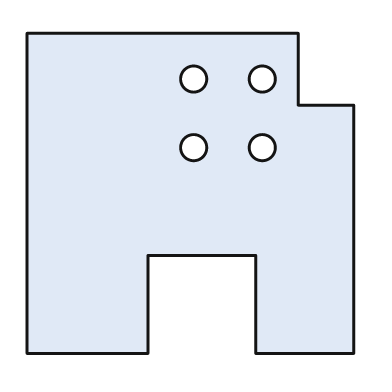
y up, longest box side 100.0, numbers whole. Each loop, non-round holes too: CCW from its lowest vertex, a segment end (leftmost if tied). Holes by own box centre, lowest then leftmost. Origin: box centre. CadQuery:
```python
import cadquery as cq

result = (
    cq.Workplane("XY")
    .moveTo(-50.0, -49.0)
    .lineTo(-13.0, -49.0)
    .lineTo(-13.0, -19.0)
    .lineTo(20.0, -19.0)
    .lineTo(20.0, -49.0)
    .lineTo(50.0, -49.0)
    .lineTo(50.0, 27.0)
    .lineTo(33.0, 27.0)
    .lineTo(33.0, 49.0)
    .lineTo(-50.0, 49.0)
    .close()
    .moveTo(1.0, 14.0)
    .circle(4.0)
    .moveTo(22.0, 14.0)
    .circle(4.0)
    .moveTo(1.0, 35.0)
    .circle(4.0)
    .moveTo(22.0, 35.0)
    .circle(4.0)
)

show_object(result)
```